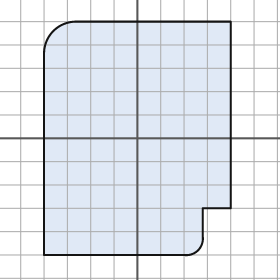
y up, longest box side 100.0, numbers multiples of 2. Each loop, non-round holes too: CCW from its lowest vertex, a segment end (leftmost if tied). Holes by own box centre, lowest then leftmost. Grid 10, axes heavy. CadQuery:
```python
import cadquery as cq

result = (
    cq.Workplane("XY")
    .moveTo(-40.0, -50.0)
    .lineTo(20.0, -50.0)
    .threePointArc((26.0, -48.0), (28.0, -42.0))
    .lineTo(28.0, -30.0)
    .lineTo(40.0, -30.0)
    .lineTo(40.0, 50.0)
    .lineTo(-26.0, 50.0)
    .threePointArc((-36.0, 46.0), (-40.0, 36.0))
    .close()
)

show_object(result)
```